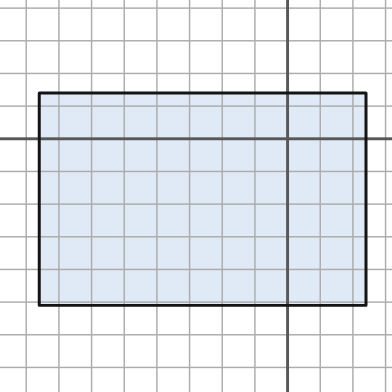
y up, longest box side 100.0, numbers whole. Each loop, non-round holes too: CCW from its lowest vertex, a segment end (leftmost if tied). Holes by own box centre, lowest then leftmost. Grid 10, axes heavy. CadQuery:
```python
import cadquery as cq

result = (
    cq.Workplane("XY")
    .moveTo(-76.0, -51.0)
    .lineTo(24.0, -51.0)
    .lineTo(24.0, 14.0)
    .lineTo(-76.0, 14.0)
    .close()
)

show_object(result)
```